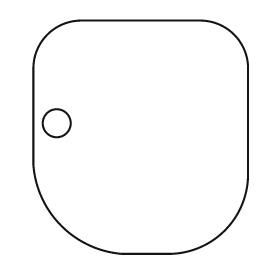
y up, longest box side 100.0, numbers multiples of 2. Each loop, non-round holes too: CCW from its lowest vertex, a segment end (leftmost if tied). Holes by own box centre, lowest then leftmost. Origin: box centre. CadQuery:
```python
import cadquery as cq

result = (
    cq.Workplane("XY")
    .moveTo(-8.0, -50.0)
    .lineTo(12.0, -50.0)
    .threePointArc((36.0, -40.0), (46.0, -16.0))
    .lineTo(46.0, 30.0)
    .threePointArc((40.0, 44.0), (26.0, 50.0))
    .lineTo(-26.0, 50.0)
    .threePointArc((-40.0, 44.0), (-46.0, 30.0))
    .lineTo(-46.0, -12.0)
    .threePointArc((-34.0, -38.0), (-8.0, -50.0))
    .close()
    .moveTo(-36.0, 6.0)
    .circle(6.0)
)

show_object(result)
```